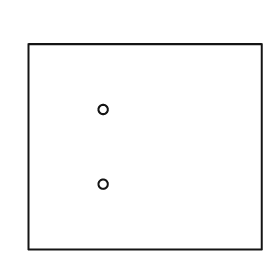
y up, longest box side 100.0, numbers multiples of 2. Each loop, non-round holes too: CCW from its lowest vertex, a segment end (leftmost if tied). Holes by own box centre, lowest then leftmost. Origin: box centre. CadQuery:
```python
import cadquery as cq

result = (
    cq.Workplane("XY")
    .moveTo(-50.0, -44.0)
    .lineTo(50.0, -44.0)
    .lineTo(50.0, 44.0)
    .lineTo(-50.0, 44.0)
    .close()
    .moveTo(-18.0, -16.0)
    .circle(2.0)
    .moveTo(-18.0, 16.0)
    .circle(2.0)
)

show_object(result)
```